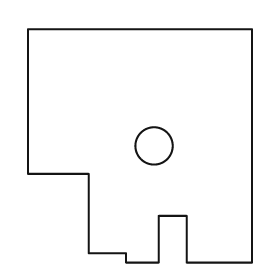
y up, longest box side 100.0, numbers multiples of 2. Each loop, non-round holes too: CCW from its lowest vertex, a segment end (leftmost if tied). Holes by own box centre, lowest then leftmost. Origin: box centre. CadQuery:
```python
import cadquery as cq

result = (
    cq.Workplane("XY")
    .moveTo(-6.0, -50.0)
    .lineTo(8.0, -50.0)
    .lineTo(8.0, -30.0)
    .lineTo(20.0, -30.0)
    .lineTo(20.0, -50.0)
    .lineTo(48.0, -50.0)
    .lineTo(48.0, 50.0)
    .lineTo(-48.0, 50.0)
    .lineTo(-48.0, -12.0)
    .lineTo(-22.0, -12.0)
    .lineTo(-22.0, -46.0)
    .lineTo(-6.0, -46.0)
    .close()
    .moveTo(6.0, 0.0)
    .circle(8.0)
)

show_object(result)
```